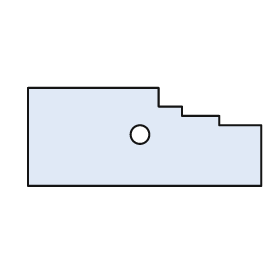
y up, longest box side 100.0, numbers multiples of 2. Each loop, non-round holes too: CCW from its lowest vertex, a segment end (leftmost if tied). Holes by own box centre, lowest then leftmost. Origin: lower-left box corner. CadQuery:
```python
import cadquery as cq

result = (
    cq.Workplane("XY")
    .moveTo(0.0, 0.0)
    .lineTo(100.0, 0.0)
    .lineTo(100.0, 26.0)
    .lineTo(82.0, 26.0)
    .lineTo(82.0, 30.0)
    .lineTo(66.0, 30.0)
    .lineTo(66.0, 34.0)
    .lineTo(56.0, 34.0)
    .lineTo(56.0, 42.0)
    .lineTo(0.0, 42.0)
    .close()
    .moveTo(48.0, 22.0)
    .circle(4.0)
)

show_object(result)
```